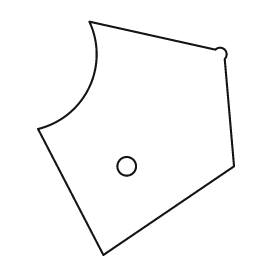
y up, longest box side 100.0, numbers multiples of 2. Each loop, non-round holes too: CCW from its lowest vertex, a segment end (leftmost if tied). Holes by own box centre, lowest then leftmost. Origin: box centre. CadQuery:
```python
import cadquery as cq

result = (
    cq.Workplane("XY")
    .moveTo(-14.0, -50.0)
    .lineTo(42.0, -12.0)
    .lineTo(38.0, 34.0)
    .threePointArc((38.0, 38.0), (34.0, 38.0))
    .lineTo(-20.0, 50.0)
    .threePointArc((-20.0, 22.0), (-42.0, 4.0))
    .close()
    .moveTo(-4.0, -12.0)
    .circle(4.0)
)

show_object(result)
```